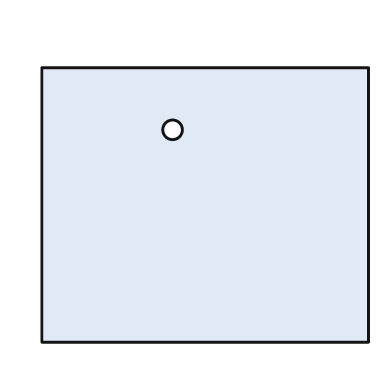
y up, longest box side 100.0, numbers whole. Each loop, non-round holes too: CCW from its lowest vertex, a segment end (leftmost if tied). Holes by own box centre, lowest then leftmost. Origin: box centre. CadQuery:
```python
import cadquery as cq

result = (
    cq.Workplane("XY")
    .moveTo(-50.0, -42.0)
    .lineTo(50.0, -42.0)
    .lineTo(50.0, 42.0)
    .lineTo(-50.0, 42.0)
    .close()
    .moveTo(-10.0, 23.0)
    .circle(3.0)
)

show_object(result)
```